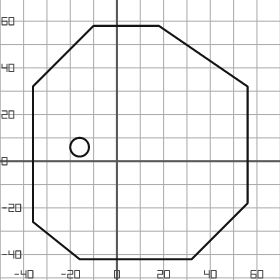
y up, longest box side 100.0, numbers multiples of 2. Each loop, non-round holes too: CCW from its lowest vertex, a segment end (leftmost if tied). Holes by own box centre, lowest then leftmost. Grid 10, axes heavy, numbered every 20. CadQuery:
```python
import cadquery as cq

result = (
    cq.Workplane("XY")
    .moveTo(-16.0, -42.0)
    .lineTo(32.0, -42.0)
    .lineTo(56.0, -18.0)
    .lineTo(56.0, 32.0)
    .lineTo(18.0, 58.0)
    .lineTo(-10.0, 58.0)
    .lineTo(-36.0, 32.0)
    .lineTo(-36.0, -26.0)
    .close()
    .moveTo(-16.0, 6.0)
    .circle(4.0)
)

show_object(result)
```